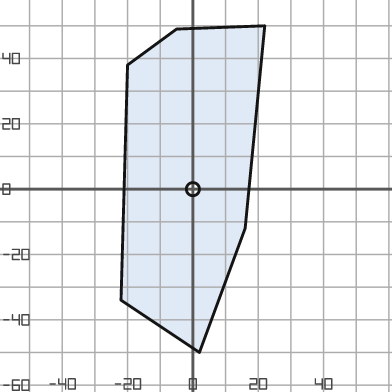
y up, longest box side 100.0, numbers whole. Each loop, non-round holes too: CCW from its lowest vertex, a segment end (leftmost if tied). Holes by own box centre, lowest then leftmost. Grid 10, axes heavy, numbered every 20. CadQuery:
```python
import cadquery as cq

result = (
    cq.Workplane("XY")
    .moveTo(2.0, -50.0)
    .lineTo(16.0, -12.0)
    .lineTo(22.0, 50.0)
    .lineTo(-5.0, 49.0)
    .lineTo(-20.0, 38.0)
    .lineTo(-22.0, -34.0)
    .close()
    .moveTo(0.0, 0.0)
    .circle(2.0)
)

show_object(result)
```